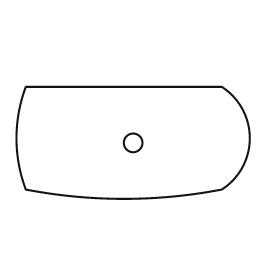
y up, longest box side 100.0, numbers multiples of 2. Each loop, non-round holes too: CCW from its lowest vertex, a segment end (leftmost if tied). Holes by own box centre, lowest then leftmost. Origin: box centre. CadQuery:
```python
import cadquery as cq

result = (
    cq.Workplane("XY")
    .moveTo(-46.0, -20.0)
    .threePointArc((-4.0, -24.0), (38.0, -20.0))
    .threePointArc((50.0, 2.0), (38.0, 24.0))
    .lineTo(-46.0, 24.0)
    .threePointArc((-50.0, 2.0), (-46.0, -20.0))
    .close()
    .moveTo(0.0, 0.0)
    .circle(4.0)
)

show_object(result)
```